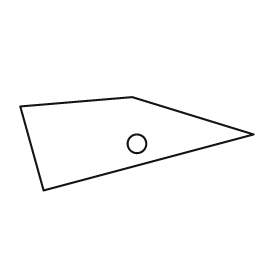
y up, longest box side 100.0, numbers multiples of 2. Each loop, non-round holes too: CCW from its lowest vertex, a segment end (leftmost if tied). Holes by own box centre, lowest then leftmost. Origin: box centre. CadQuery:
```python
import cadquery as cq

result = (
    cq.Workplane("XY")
    .moveTo(-40.0, -20.0)
    .lineTo(50.0, 4.0)
    .lineTo(-2.0, 20.0)
    .lineTo(-50.0, 16.0)
    .close()
    .moveTo(0.0, 0.0)
    .circle(4.0)
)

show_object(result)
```